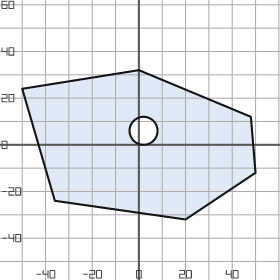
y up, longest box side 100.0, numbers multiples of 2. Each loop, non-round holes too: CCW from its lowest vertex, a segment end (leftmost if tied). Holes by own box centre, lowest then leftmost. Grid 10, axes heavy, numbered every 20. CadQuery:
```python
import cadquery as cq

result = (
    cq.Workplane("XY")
    .moveTo(20.0, -32.0)
    .lineTo(50.0, -12.0)
    .lineTo(48.0, 12.0)
    .lineTo(0.0, 32.0)
    .lineTo(-50.0, 24.0)
    .lineTo(-36.0, -24.0)
    .close()
    .moveTo(2.0, 6.0)
    .circle(6.0)
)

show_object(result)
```